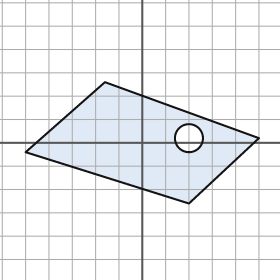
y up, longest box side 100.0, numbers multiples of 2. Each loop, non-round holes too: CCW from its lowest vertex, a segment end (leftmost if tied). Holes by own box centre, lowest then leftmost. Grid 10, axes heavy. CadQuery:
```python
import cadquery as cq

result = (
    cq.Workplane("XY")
    .moveTo(20.0, -26.0)
    .lineTo(50.0, 2.0)
    .lineTo(-16.0, 26.0)
    .lineTo(-50.0, -4.0)
    .close()
    .moveTo(20.0, 2.0)
    .circle(6.0)
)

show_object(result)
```